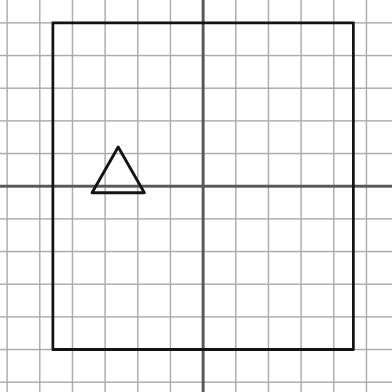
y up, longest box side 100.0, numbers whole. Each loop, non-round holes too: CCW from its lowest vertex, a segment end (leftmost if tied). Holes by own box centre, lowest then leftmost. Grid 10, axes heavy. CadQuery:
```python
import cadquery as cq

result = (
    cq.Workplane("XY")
    .moveTo(-46.0, -50.0)
    .lineTo(46.0, -50.0)
    .lineTo(46.0, 50.0)
    .lineTo(-46.0, 50.0)
    .close()
    .moveTo(-34.0, -2.0)
    .lineTo(-18.0, -2.0)
    .lineTo(-26.0, 12.0)
    .close()
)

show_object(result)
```